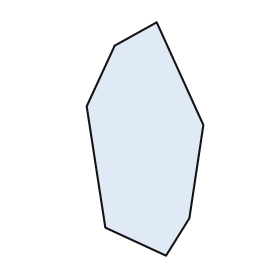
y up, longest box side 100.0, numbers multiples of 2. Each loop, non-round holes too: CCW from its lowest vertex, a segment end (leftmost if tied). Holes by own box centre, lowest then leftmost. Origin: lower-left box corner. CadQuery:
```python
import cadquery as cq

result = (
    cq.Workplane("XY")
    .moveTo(34.0, 0.0)
    .lineTo(44.0, 16.0)
    .lineTo(50.0, 56.0)
    .lineTo(30.0, 100.0)
    .lineTo(12.0, 90.0)
    .lineTo(0.0, 64.0)
    .lineTo(8.0, 12.0)
    .close()
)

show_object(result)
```